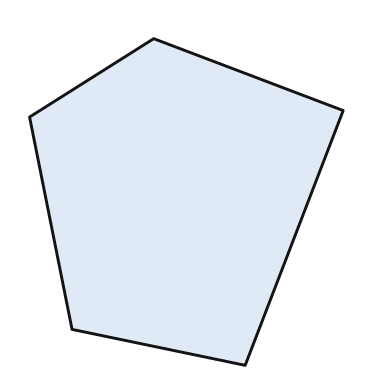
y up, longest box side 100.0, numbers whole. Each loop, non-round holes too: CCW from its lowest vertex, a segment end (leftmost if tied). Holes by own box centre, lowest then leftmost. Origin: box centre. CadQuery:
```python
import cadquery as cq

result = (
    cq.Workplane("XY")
    .moveTo(18.0, -50.0)
    .lineTo(48.0, 28.0)
    .lineTo(-10.0, 50.0)
    .lineTo(-48.0, 26.0)
    .lineTo(-35.0, -39.0)
    .close()
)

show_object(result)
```